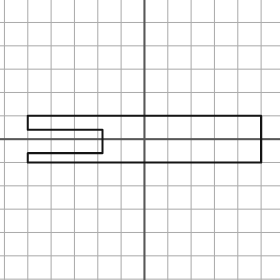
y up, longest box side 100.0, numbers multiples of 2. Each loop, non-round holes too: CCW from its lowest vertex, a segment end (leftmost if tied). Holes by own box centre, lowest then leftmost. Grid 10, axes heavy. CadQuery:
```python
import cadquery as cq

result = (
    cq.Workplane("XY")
    .moveTo(-50.0, -10.0)
    .lineTo(50.0, -10.0)
    .lineTo(50.0, 10.0)
    .lineTo(-50.0, 10.0)
    .lineTo(-50.0, 4.0)
    .lineTo(-18.0, 4.0)
    .lineTo(-18.0, -6.0)
    .lineTo(-50.0, -6.0)
    .close()
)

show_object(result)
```